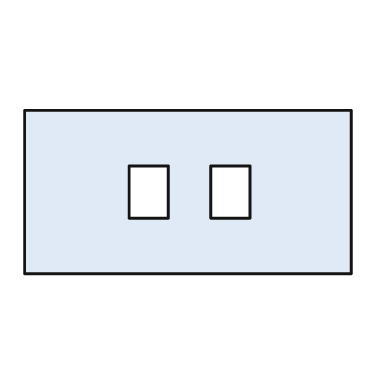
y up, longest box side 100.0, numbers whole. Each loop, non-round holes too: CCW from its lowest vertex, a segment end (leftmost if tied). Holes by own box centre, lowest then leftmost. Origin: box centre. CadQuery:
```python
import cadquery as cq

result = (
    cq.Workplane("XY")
    .moveTo(-50.0, -25.0)
    .lineTo(50.0, -25.0)
    .lineTo(50.0, 25.0)
    .lineTo(-50.0, 25.0)
    .close()
    .moveTo(-18.0, -8.0)
    .lineTo(-6.0, -8.0)
    .lineTo(-6.0, 8.0)
    .lineTo(-18.0, 8.0)
    .close()
    .moveTo(7.0, -8.0)
    .lineTo(19.0, -8.0)
    .lineTo(19.0, 8.0)
    .lineTo(7.0, 8.0)
    .close()
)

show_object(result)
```